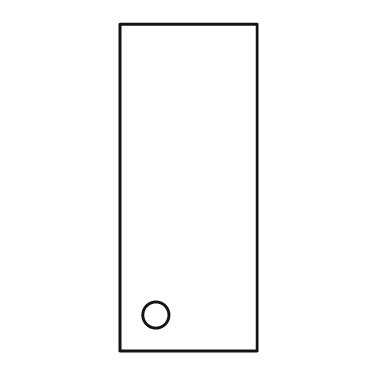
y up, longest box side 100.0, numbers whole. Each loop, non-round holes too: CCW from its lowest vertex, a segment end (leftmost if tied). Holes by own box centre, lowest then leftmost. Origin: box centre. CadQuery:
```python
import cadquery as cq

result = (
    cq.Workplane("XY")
    .moveTo(-21.0, -50.0)
    .lineTo(21.0, -50.0)
    .lineTo(21.0, 50.0)
    .lineTo(-21.0, 50.0)
    .close()
    .moveTo(-10.0, -39.0)
    .circle(4.0)
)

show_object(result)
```